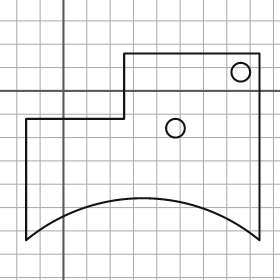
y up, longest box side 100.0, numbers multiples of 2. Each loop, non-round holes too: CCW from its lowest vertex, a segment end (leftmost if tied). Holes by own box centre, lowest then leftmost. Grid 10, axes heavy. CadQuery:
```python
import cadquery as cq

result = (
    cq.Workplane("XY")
    .moveTo(-16.0, -64.0)
    .threePointArc((34.0, -46.0), (84.0, -64.0))
    .lineTo(84.0, 16.0)
    .lineTo(26.0, 16.0)
    .lineTo(26.0, -12.0)
    .lineTo(-16.0, -12.0)
    .close()
    .moveTo(48.0, -16.0)
    .circle(4.0)
    .moveTo(76.0, 8.0)
    .circle(4.0)
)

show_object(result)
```